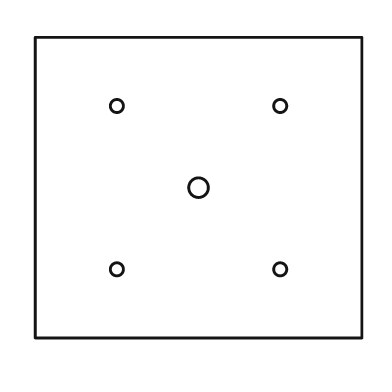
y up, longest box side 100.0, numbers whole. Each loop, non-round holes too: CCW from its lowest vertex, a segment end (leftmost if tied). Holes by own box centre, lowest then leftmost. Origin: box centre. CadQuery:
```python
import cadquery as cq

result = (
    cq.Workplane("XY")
    .moveTo(-50.0, -46.0)
    .lineTo(50.0, -46.0)
    .lineTo(50.0, 46.0)
    .lineTo(-50.0, 46.0)
    .close()
    .moveTo(-25.0, -25.0)
    .circle(2.0)
    .moveTo(25.0, -25.0)
    .circle(2.0)
    .moveTo(0.0, 0.0)
    .circle(3.0)
    .moveTo(-25.0, 25.0)
    .circle(2.0)
    .moveTo(25.0, 25.0)
    .circle(2.0)
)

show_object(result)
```